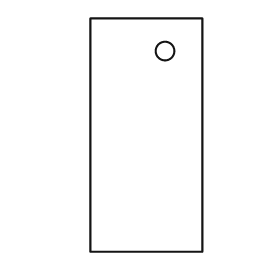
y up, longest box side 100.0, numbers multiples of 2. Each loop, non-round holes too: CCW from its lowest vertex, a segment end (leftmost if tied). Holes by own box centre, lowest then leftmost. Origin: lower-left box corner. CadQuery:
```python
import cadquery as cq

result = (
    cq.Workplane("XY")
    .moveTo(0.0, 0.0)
    .lineTo(48.0, 0.0)
    .lineTo(48.0, 100.0)
    .lineTo(0.0, 100.0)
    .close()
    .moveTo(32.0, 86.0)
    .circle(4.0)
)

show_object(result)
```